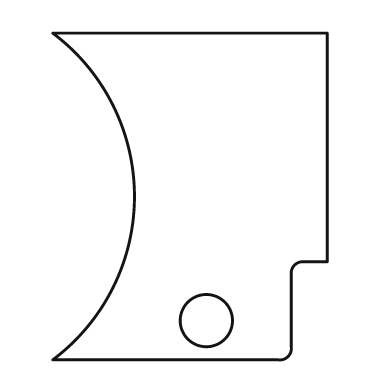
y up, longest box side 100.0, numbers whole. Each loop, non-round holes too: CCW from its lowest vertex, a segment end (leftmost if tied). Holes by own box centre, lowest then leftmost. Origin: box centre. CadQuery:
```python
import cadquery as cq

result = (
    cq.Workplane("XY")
    .moveTo(-42.0, -50.0)
    .lineTo(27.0, -50.0)
    .threePointArc((30.0, -49.0), (31.0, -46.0))
    .lineTo(31.0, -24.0)
    .threePointArc((32.0, -21.0), (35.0, -20.0))
    .lineTo(42.0, -20.0)
    .lineTo(42.0, 50.0)
    .lineTo(-42.0, 50.0)
    .threePointArc((-17.0, 0.0), (-42.0, -50.0))
    .close()
    .moveTo(5.0, -38.0)
    .circle(8.0)
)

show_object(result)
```